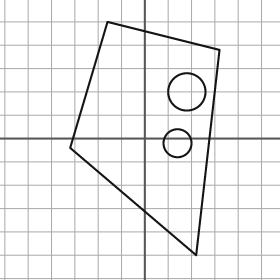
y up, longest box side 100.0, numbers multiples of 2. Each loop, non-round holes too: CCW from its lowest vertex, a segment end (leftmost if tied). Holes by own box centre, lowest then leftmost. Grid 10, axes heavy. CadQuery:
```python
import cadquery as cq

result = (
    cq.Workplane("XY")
    .moveTo(22.0, -50.0)
    .lineTo(32.0, 38.0)
    .lineTo(-16.0, 50.0)
    .lineTo(-32.0, -4.0)
    .close()
    .moveTo(14.0, -2.0)
    .circle(6.0)
    .moveTo(18.0, 20.0)
    .circle(8.0)
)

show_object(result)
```